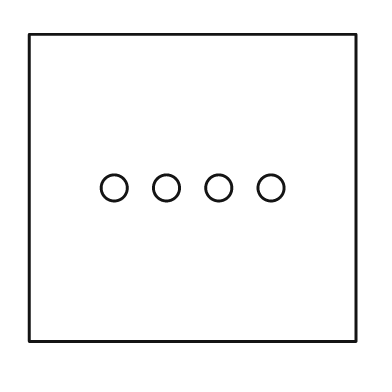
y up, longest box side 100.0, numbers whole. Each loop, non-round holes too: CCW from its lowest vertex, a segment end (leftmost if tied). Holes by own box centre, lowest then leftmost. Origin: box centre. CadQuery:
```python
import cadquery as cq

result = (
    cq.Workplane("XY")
    .moveTo(-50.0, -47.0)
    .lineTo(50.0, -47.0)
    .lineTo(50.0, 47.0)
    .lineTo(-50.0, 47.0)
    .close()
    .moveTo(-24.0, 0.0)
    .circle(4.0)
    .moveTo(-8.0, 0.0)
    .circle(4.0)
    .moveTo(8.0, 0.0)
    .circle(4.0)
    .moveTo(24.0, 0.0)
    .circle(4.0)
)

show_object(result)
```